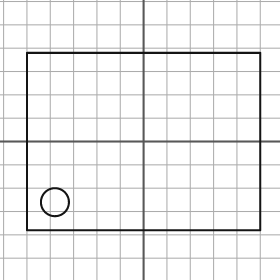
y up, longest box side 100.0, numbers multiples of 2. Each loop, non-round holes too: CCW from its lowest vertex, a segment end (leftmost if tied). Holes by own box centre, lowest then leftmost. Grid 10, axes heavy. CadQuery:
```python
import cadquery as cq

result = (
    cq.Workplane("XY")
    .moveTo(-50.0, -38.0)
    .lineTo(50.0, -38.0)
    .lineTo(50.0, 38.0)
    .lineTo(-50.0, 38.0)
    .close()
    .moveTo(-38.0, -26.0)
    .circle(6.0)
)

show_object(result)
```